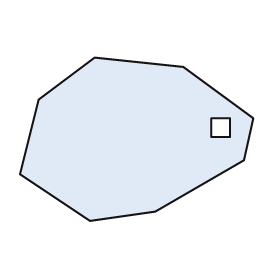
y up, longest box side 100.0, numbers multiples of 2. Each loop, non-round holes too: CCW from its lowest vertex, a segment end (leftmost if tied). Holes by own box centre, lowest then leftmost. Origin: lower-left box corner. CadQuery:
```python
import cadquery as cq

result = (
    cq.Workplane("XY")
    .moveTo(30.0, 0.0)
    .lineTo(58.0, 4.0)
    .lineTo(96.0, 26.0)
    .lineTo(100.0, 44.0)
    .lineTo(70.0, 66.0)
    .lineTo(32.0, 70.0)
    .lineTo(8.0, 52.0)
    .lineTo(0.0, 20.0)
    .close()
    .moveTo(82.0, 36.0)
    .lineTo(90.0, 36.0)
    .lineTo(90.0, 44.0)
    .lineTo(82.0, 44.0)
    .close()
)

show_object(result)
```